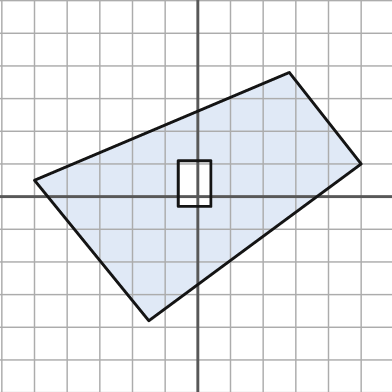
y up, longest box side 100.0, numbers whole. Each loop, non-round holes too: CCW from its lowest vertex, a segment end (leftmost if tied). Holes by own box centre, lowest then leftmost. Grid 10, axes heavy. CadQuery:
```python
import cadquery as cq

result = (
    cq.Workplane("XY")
    .moveTo(-15.0, -38.0)
    .lineTo(50.0, 10.0)
    .lineTo(28.0, 38.0)
    .lineTo(-50.0, 5.0)
    .close()
    .moveTo(-6.0, -3.0)
    .lineTo(4.0, -3.0)
    .lineTo(4.0, 11.0)
    .lineTo(-6.0, 11.0)
    .close()
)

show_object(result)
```